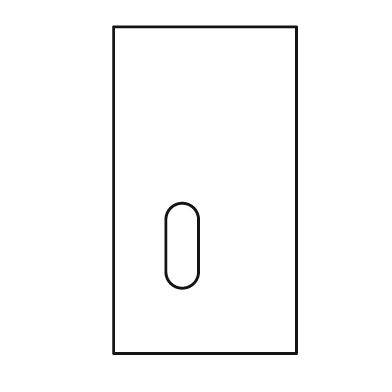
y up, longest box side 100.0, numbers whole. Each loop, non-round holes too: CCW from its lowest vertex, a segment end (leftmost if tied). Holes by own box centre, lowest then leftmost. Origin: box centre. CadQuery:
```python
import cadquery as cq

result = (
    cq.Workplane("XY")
    .moveTo(-28.0, -50.0)
    .lineTo(28.0, -50.0)
    .lineTo(28.0, 50.0)
    .lineTo(-28.0, 50.0)
    .close()
    .moveTo(-12.0, -25.0)
    .threePointArc((-7.0, -30.0), (-2.0, -25.0))
    .lineTo(-2.0, -9.0)
    .threePointArc((-7.0, -4.0), (-12.0, -9.0))
    .close()
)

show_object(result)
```